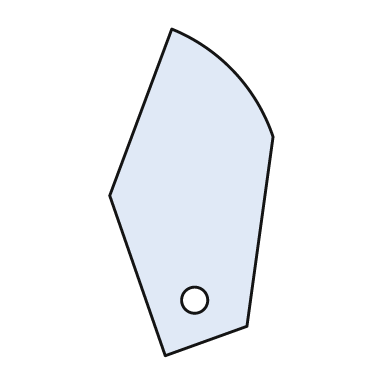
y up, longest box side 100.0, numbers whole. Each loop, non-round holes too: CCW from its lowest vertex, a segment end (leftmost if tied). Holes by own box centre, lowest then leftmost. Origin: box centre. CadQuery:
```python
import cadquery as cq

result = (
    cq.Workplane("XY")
    .moveTo(-8.0, -50.0)
    .lineTo(17.0, -41.0)
    .lineTo(25.0, 17.0)
    .threePointArc((13.0, 37.0), (-6.0, 50.0))
    .lineTo(-25.0, -1.0)
    .close()
    .moveTo(1.0, -33.0)
    .circle(4.0)
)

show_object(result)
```